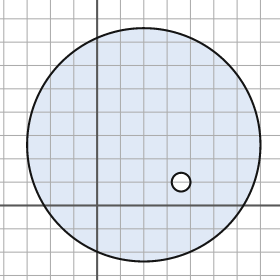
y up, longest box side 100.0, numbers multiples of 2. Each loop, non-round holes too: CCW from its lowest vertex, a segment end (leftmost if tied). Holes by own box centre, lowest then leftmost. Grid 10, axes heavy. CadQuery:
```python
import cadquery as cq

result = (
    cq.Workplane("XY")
    .moveTo(20.0, 26.0)
    .circle(50.0)
    .moveTo(36.0, 10.0)
    .circle(4.0)
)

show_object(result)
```